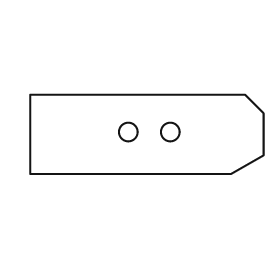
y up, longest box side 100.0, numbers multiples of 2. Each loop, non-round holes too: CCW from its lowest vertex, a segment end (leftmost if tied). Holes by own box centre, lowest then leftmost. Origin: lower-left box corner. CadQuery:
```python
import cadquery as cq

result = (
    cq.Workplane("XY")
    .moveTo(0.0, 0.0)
    .lineTo(86.0, 0.0)
    .lineTo(100.0, 8.0)
    .lineTo(100.0, 26.0)
    .lineTo(92.0, 34.0)
    .lineTo(0.0, 34.0)
    .close()
    .moveTo(42.0, 18.0)
    .circle(4.0)
    .moveTo(60.0, 18.0)
    .circle(4.0)
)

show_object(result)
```